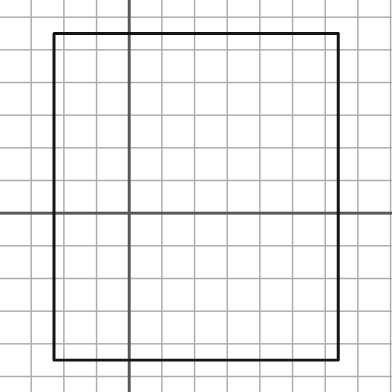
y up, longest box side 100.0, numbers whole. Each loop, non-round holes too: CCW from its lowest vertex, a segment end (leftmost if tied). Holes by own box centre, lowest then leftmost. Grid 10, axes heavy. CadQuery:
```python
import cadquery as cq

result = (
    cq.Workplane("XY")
    .moveTo(-23.0, -45.0)
    .lineTo(64.0, -45.0)
    .lineTo(64.0, 55.0)
    .lineTo(-23.0, 55.0)
    .close()
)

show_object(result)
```